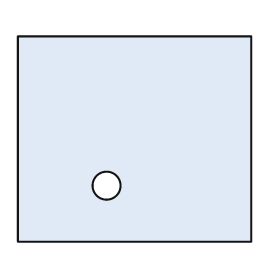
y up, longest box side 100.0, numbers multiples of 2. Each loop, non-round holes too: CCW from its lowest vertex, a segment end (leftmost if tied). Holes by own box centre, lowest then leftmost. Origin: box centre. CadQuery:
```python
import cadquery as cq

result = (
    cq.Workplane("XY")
    .moveTo(-50.0, -44.0)
    .lineTo(50.0, -44.0)
    .lineTo(50.0, 44.0)
    .lineTo(-50.0, 44.0)
    .close()
    .moveTo(-12.0, -20.0)
    .circle(6.0)
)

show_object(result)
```